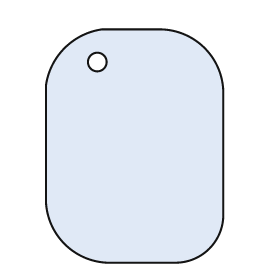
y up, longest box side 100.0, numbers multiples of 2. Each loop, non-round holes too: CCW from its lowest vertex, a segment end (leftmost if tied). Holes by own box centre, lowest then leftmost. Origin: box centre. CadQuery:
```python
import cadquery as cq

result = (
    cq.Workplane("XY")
    .moveTo(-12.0, -50.0)
    .lineTo(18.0, -50.0)
    .threePointArc((32.0, -44.0), (38.0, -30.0))
    .lineTo(38.0, 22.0)
    .threePointArc((30.0, 42.0), (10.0, 50.0))
    .lineTo(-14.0, 50.0)
    .threePointArc((-30.0, 42.0), (-38.0, 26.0))
    .lineTo(-38.0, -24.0)
    .threePointArc((-30.0, -42.0), (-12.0, -50.0))
    .close()
    .moveTo(-16.0, 36.0)
    .circle(4.0)
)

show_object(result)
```